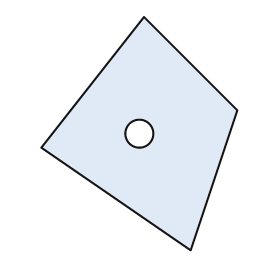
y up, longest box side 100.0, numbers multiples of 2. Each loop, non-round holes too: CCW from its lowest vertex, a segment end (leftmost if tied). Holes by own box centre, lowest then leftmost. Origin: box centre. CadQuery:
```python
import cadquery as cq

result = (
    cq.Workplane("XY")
    .moveTo(22.0, -50.0)
    .lineTo(42.0, 10.0)
    .lineTo(2.0, 50.0)
    .lineTo(-42.0, -6.0)
    .close()
    .moveTo(0.0, 0.0)
    .circle(6.0)
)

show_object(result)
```